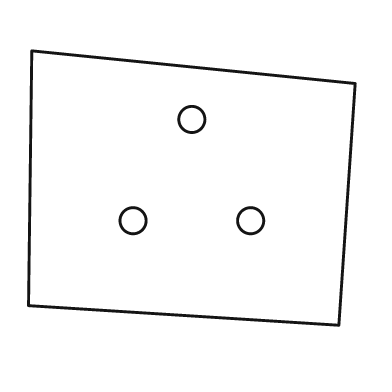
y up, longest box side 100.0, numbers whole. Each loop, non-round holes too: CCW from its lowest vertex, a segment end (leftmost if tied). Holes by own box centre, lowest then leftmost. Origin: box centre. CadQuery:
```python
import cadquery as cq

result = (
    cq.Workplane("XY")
    .moveTo(45.0, -42.0)
    .lineTo(50.0, 32.0)
    .lineTo(-49.0, 42.0)
    .lineTo(-50.0, -36.0)
    .close()
    .moveTo(-18.0, -10.0)
    .circle(4.0)
    .moveTo(18.0, -10.0)
    .circle(4.0)
    .moveTo(0.0, 21.0)
    .circle(4.0)
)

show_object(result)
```